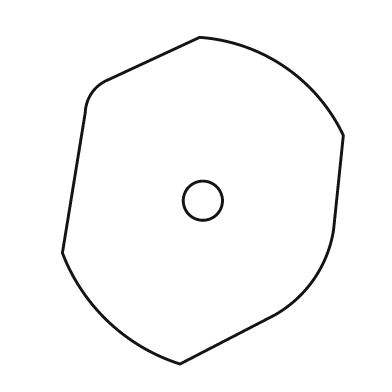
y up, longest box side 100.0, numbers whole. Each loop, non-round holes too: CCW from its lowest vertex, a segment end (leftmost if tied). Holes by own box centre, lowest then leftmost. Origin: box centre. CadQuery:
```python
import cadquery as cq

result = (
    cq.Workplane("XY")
    .moveTo(-7.0, -50.0)
    .lineTo(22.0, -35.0)
    .threePointArc((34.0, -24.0), (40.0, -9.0))
    .lineTo(43.0, 20.0)
    .threePointArc((25.0, 41.0), (-1.0, 50.0))
    .lineTo(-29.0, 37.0)
    .threePointArc((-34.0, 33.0), (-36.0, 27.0))
    .lineTo(-43.0, -16.0)
    .threePointArc((-29.0, -37.0), (-7.0, -50.0))
    .close()
    .moveTo(0.0, 0.0)
    .circle(6.0)
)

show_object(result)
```